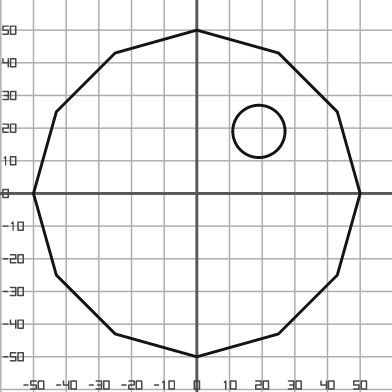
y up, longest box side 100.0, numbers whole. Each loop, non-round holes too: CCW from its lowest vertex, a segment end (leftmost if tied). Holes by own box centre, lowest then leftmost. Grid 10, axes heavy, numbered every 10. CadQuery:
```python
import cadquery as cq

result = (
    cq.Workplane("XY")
    .moveTo(0.0, -50.0)
    .lineTo(25.0, -43.0)
    .lineTo(43.0, -25.0)
    .lineTo(50.0, 0.0)
    .lineTo(43.0, 25.0)
    .lineTo(25.0, 43.0)
    .lineTo(0.0, 50.0)
    .lineTo(-25.0, 43.0)
    .lineTo(-43.0, 25.0)
    .lineTo(-50.0, 0.0)
    .lineTo(-43.0, -25.0)
    .lineTo(-25.0, -43.0)
    .close()
    .moveTo(19.0, 19.0)
    .circle(8.0)
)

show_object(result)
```